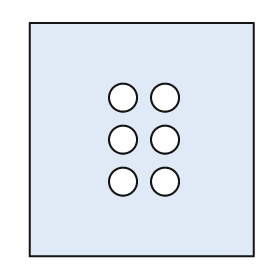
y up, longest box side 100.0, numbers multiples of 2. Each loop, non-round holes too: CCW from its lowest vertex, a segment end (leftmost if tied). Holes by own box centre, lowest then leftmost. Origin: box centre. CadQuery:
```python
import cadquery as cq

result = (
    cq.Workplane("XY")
    .moveTo(-48.0, -50.0)
    .lineTo(48.0, -50.0)
    .lineTo(48.0, 50.0)
    .lineTo(-48.0, 50.0)
    .close()
    .moveTo(-8.0, -18.0)
    .circle(6.0)
    .moveTo(10.0, -18.0)
    .circle(6.0)
    .moveTo(-8.0, 0.0)
    .circle(6.0)
    .moveTo(10.0, 0.0)
    .circle(6.0)
    .moveTo(-8.0, 18.0)
    .circle(6.0)
    .moveTo(10.0, 18.0)
    .circle(6.0)
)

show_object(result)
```